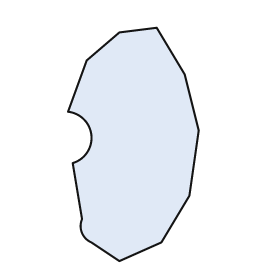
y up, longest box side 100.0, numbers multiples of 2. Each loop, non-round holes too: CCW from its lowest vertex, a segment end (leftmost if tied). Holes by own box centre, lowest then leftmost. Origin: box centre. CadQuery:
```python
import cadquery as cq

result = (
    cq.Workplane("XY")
    .moveTo(-6.0, -50.0)
    .lineTo(12.0, -42.0)
    .lineTo(24.0, -22.0)
    .lineTo(28.0, 6.0)
    .lineTo(22.0, 30.0)
    .lineTo(10.0, 50.0)
    .lineTo(-6.0, 48.0)
    .lineTo(-20.0, 36.0)
    .lineTo(-28.0, 14.0)
    .threePointArc((-18.0, 4.0), (-26.0, -8.0))
    .lineTo(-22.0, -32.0)
    .threePointArc((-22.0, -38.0), (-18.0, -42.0))
    .close()
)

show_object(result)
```